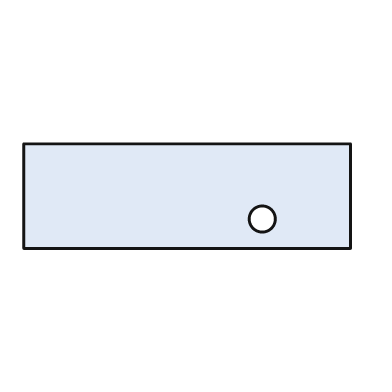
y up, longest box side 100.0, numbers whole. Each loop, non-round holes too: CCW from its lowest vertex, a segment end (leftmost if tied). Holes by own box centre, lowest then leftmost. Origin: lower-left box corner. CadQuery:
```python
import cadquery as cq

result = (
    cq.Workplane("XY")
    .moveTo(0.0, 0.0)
    .lineTo(100.0, 0.0)
    .lineTo(100.0, 32.0)
    .lineTo(0.0, 32.0)
    .close()
    .moveTo(73.0, 9.0)
    .circle(4.0)
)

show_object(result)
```